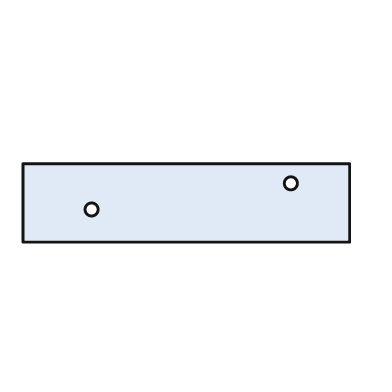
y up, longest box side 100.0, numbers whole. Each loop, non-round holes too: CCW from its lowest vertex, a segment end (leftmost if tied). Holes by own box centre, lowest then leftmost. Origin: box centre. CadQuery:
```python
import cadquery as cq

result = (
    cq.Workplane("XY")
    .moveTo(-50.0, -12.0)
    .lineTo(50.0, -12.0)
    .lineTo(50.0, 12.0)
    .lineTo(-50.0, 12.0)
    .close()
    .moveTo(-29.0, -2.0)
    .circle(2.0)
    .moveTo(32.0, 6.0)
    .circle(2.0)
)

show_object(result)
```